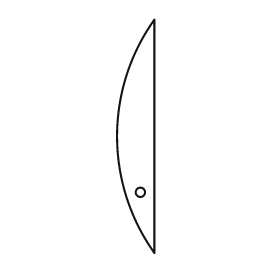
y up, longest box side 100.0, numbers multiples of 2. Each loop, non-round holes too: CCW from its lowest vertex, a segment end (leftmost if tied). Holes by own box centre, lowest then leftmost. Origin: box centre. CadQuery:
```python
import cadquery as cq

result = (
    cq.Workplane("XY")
    .moveTo(8.0, -50.0)
    .lineTo(8.0, 50.0)
    .threePointArc((-8.0, 0.0), (8.0, -50.0))
    .close()
    .moveTo(2.0, -24.0)
    .circle(2.0)
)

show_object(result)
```